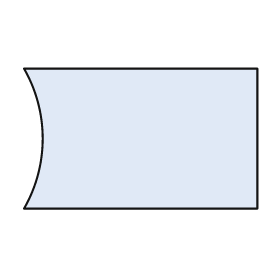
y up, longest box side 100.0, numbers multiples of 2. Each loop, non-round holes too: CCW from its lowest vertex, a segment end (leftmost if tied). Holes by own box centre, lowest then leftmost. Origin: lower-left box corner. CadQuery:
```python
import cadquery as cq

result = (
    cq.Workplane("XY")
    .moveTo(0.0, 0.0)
    .lineTo(100.0, 0.0)
    .lineTo(100.0, 60.0)
    .lineTo(0.0, 60.0)
    .threePointArc((8.0, 30.0), (0.0, 0.0))
    .close()
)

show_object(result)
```